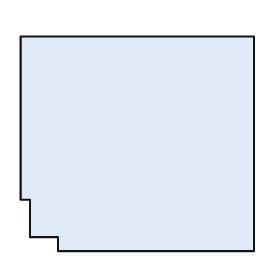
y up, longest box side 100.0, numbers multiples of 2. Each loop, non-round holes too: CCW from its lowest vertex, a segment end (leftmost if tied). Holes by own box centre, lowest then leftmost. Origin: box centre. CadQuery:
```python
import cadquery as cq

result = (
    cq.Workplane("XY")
    .moveTo(-34.0, -46.0)
    .lineTo(50.0, -46.0)
    .lineTo(50.0, 46.0)
    .lineTo(-50.0, 46.0)
    .lineTo(-50.0, -24.0)
    .lineTo(-46.0, -24.0)
    .lineTo(-46.0, -40.0)
    .lineTo(-34.0, -40.0)
    .close()
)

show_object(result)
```